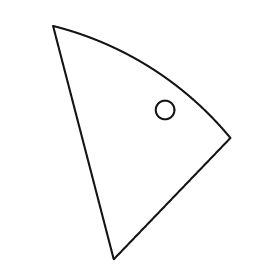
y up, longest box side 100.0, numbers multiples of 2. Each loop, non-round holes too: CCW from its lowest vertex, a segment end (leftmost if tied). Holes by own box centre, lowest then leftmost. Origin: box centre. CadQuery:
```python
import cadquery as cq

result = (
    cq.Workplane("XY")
    .moveTo(-12.0, -50.0)
    .lineTo(38.0, 2.0)
    .threePointArc((4.0, 32.0), (-38.0, 50.0))
    .close()
    .moveTo(10.0, 14.0)
    .circle(4.0)
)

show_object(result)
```